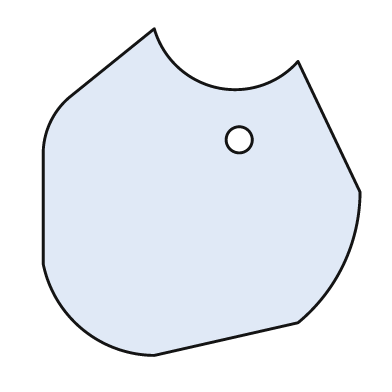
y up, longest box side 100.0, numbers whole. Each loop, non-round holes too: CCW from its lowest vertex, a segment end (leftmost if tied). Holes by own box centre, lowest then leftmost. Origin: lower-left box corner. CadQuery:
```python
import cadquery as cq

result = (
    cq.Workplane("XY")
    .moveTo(34.0, 0.0)
    .lineTo(78.0, 10.0)
    .threePointArc((92.0, 28.0), (97.0, 50.0))
    .lineTo(78.0, 90.0)
    .threePointArc((53.0, 82.0), (34.0, 100.0))
    .lineTo(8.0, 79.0)
    .threePointArc((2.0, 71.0), (0.0, 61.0))
    .lineTo(0.0, 28.0)
    .threePointArc((12.0, 8.0), (34.0, 0.0))
    .close()
    .moveTo(60.0, 66.0)
    .circle(4.0)
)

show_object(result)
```